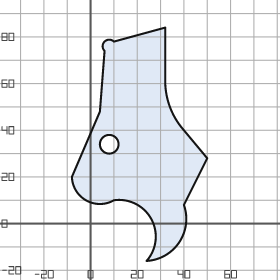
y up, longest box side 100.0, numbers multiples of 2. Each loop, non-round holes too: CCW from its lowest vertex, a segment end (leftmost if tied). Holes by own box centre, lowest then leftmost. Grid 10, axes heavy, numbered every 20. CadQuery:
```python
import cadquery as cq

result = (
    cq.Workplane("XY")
    .moveTo(24.0, -16.0)
    .threePointArc((38.0, -8.0), (40.0, 8.0))
    .lineTo(50.0, 28.0)
    .lineTo(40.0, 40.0)
    .threePointArc((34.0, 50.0), (32.0, 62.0))
    .lineTo(32.0, 84.0)
    .lineTo(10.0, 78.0)
    .threePointArc((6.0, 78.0), (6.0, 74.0))
    .lineTo(4.0, 48.0)
    .lineTo(-8.0, 20.0)
    .threePointArc((-2.0, 10.0), (10.0, 10.0))
    .threePointArc((26.0, 2.0), (24.0, -16.0))
    .close()
    .moveTo(8.0, 34.0)
    .circle(4.0)
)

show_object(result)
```